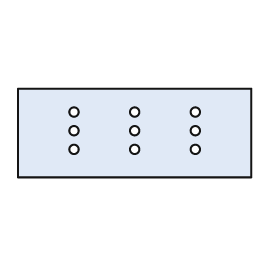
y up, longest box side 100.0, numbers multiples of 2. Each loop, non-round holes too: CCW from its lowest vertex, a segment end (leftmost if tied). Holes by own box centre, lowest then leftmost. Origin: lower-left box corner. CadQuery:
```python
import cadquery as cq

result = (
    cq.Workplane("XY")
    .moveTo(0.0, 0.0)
    .lineTo(100.0, 0.0)
    .lineTo(100.0, 38.0)
    .lineTo(0.0, 38.0)
    .close()
    .moveTo(24.0, 12.0)
    .circle(2.0)
    .moveTo(50.0, 12.0)
    .circle(2.0)
    .moveTo(76.0, 12.0)
    .circle(2.0)
    .moveTo(24.0, 20.0)
    .circle(2.0)
    .moveTo(50.0, 20.0)
    .circle(2.0)
    .moveTo(76.0, 20.0)
    .circle(2.0)
    .moveTo(24.0, 28.0)
    .circle(2.0)
    .moveTo(50.0, 28.0)
    .circle(2.0)
    .moveTo(76.0, 28.0)
    .circle(2.0)
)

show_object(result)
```